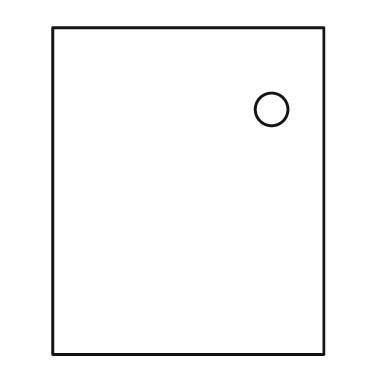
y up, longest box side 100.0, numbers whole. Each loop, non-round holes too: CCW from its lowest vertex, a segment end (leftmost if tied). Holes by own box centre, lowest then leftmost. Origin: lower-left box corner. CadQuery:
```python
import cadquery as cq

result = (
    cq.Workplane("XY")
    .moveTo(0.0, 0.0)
    .lineTo(83.0, 0.0)
    .lineTo(83.0, 100.0)
    .lineTo(0.0, 100.0)
    .close()
    .moveTo(67.0, 75.0)
    .circle(5.0)
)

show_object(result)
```